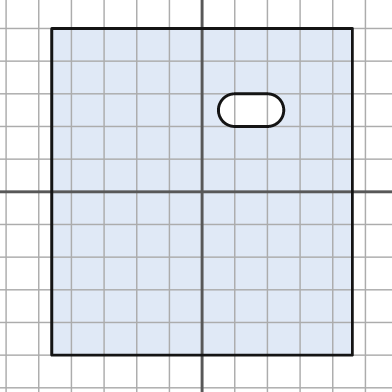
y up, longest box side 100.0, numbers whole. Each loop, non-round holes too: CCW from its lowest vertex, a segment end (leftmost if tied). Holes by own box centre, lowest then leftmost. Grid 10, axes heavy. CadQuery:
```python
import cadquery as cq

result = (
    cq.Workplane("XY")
    .moveTo(-46.0, -50.0)
    .lineTo(46.0, -50.0)
    .lineTo(46.0, 50.0)
    .lineTo(-46.0, 50.0)
    .close()
    .moveTo(10.0, 20.0)
    .lineTo(20.0, 20.0)
    .threePointArc((25.0, 25.0), (20.0, 30.0))
    .lineTo(10.0, 30.0)
    .threePointArc((5.0, 25.0), (10.0, 20.0))
    .close()
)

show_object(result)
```